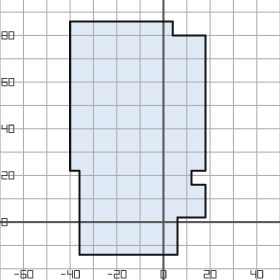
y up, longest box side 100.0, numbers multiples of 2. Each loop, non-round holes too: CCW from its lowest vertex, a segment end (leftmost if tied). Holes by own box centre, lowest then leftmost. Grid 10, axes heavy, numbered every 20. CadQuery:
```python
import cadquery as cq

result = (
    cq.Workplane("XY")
    .moveTo(-36.0, -14.0)
    .lineTo(6.0, -14.0)
    .lineTo(6.0, 2.0)
    .lineTo(18.0, 2.0)
    .lineTo(18.0, 16.0)
    .lineTo(12.0, 16.0)
    .lineTo(12.0, 22.0)
    .lineTo(18.0, 22.0)
    .lineTo(18.0, 80.0)
    .lineTo(4.0, 80.0)
    .lineTo(4.0, 86.0)
    .lineTo(-40.0, 86.0)
    .lineTo(-40.0, 22.0)
    .lineTo(-36.0, 22.0)
    .close()
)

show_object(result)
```